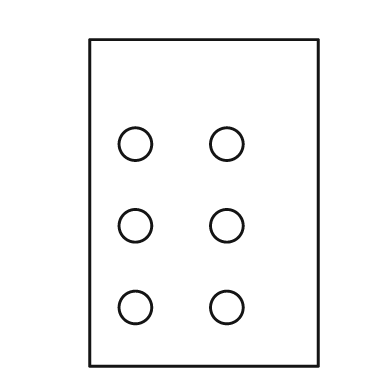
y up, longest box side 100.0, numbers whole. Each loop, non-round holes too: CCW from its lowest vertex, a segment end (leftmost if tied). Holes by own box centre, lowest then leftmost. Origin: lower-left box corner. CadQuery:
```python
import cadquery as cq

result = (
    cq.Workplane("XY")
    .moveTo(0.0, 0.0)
    .lineTo(70.0, 0.0)
    .lineTo(70.0, 100.0)
    .lineTo(0.0, 100.0)
    .close()
    .moveTo(14.0, 18.0)
    .circle(5.0)
    .moveTo(42.0, 18.0)
    .circle(5.0)
    .moveTo(14.0, 43.0)
    .circle(5.0)
    .moveTo(42.0, 43.0)
    .circle(5.0)
    .moveTo(14.0, 68.0)
    .circle(5.0)
    .moveTo(42.0, 68.0)
    .circle(5.0)
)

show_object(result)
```